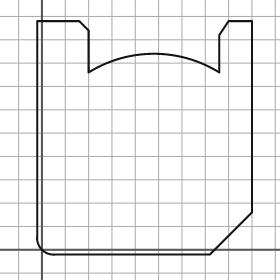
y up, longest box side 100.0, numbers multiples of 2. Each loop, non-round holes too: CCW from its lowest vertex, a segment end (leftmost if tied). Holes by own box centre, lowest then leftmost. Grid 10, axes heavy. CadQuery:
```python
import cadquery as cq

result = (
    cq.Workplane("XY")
    .moveTo(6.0, -2.0)
    .lineTo(72.0, -2.0)
    .lineTo(90.0, 16.0)
    .lineTo(90.0, 98.0)
    .lineTo(80.0, 98.0)
    .lineTo(76.0, 92.0)
    .lineTo(76.0, 76.0)
    .threePointArc((48.0, 84.0), (20.0, 76.0))
    .lineTo(20.0, 94.0)
    .lineTo(16.0, 98.0)
    .lineTo(-2.0, 98.0)
    .lineTo(-2.0, 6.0)
    .threePointArc((0.0, 0.0), (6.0, -2.0))
    .close()
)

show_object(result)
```